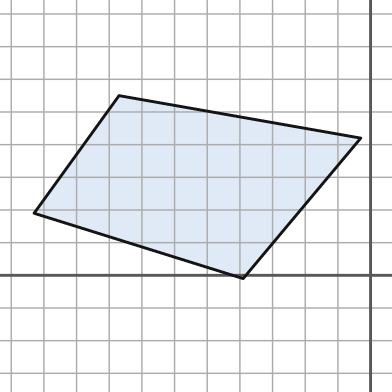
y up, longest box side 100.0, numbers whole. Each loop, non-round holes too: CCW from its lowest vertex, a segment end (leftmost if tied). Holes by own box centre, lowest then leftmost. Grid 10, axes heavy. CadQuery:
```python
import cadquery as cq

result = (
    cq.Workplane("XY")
    .moveTo(-39.0, -1.0)
    .lineTo(-3.0, 42.0)
    .lineTo(-77.0, 55.0)
    .lineTo(-103.0, 19.0)
    .close()
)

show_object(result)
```